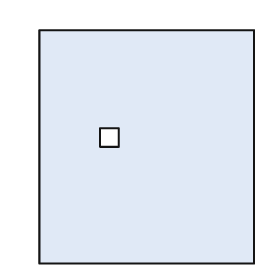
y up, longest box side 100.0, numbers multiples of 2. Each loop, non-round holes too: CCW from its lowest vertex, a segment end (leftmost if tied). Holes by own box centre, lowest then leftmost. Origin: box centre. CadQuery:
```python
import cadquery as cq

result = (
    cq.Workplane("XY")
    .moveTo(-46.0, -50.0)
    .lineTo(46.0, -50.0)
    .lineTo(46.0, 50.0)
    .lineTo(-46.0, 50.0)
    .close()
    .moveTo(-20.0, 0.0)
    .lineTo(-12.0, 0.0)
    .lineTo(-12.0, 8.0)
    .lineTo(-20.0, 8.0)
    .close()
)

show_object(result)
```